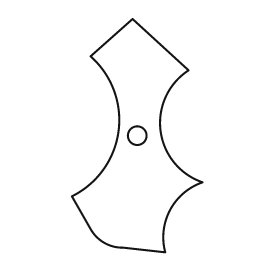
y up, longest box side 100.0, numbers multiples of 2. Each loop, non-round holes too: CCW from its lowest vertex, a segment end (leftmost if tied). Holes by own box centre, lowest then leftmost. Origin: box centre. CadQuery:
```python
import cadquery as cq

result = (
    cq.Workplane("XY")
    .moveTo(12.0, -50.0)
    .threePointArc((14.0, -32.0), (28.0, -20.0))
    .threePointArc((10.0, 2.0), (22.0, 28.0))
    .lineTo(-2.0, 50.0)
    .lineTo(-20.0, 34.0)
    .threePointArc((-8.0, 2.0), (-28.0, -26.0))
    .lineTo(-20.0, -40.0)
    .threePointArc((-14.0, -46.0), (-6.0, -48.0))
    .close()
    .moveTo(0.0, 0.0)
    .circle(4.0)
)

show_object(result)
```